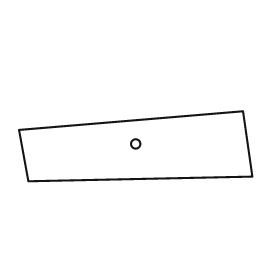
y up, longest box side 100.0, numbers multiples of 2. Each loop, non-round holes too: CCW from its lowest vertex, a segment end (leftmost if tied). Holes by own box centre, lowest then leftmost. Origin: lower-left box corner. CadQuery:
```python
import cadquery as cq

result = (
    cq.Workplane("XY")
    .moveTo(4.0, 0.0)
    .lineTo(100.0, 2.0)
    .lineTo(96.0, 30.0)
    .lineTo(0.0, 22.0)
    .close()
    .moveTo(50.0, 16.0)
    .circle(2.0)
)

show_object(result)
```